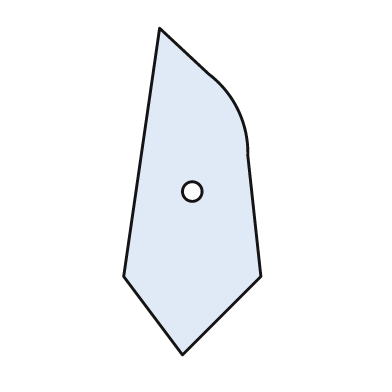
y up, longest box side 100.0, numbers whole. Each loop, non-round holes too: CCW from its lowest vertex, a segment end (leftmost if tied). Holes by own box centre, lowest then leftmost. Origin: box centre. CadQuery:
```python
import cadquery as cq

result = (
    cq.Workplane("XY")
    .moveTo(-3.0, -50.0)
    .lineTo(21.0, -26.0)
    .lineTo(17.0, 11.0)
    .threePointArc((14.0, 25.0), (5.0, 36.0))
    .lineTo(-10.0, 50.0)
    .lineTo(-21.0, -26.0)
    .close()
    .moveTo(0.0, 0.0)
    .circle(3.0)
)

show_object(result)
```